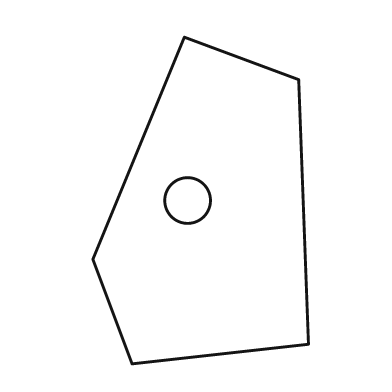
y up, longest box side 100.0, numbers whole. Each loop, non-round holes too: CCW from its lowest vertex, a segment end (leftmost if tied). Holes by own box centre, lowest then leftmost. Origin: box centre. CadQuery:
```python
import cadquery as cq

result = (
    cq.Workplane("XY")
    .moveTo(-21.0, -50.0)
    .lineTo(33.0, -44.0)
    .lineTo(30.0, 37.0)
    .lineTo(-5.0, 50.0)
    .lineTo(-33.0, -18.0)
    .close()
    .moveTo(-4.0, 0.0)
    .circle(7.0)
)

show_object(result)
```